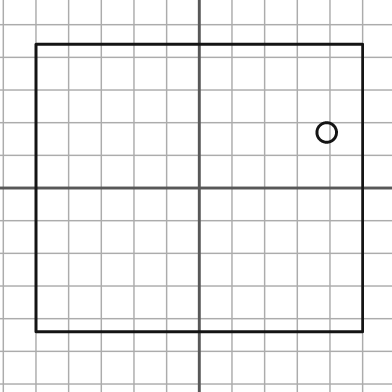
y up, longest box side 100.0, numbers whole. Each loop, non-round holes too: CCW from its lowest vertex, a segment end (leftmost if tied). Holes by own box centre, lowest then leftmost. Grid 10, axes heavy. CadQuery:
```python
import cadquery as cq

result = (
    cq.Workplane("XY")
    .moveTo(-50.0, -44.0)
    .lineTo(50.0, -44.0)
    .lineTo(50.0, 44.0)
    .lineTo(-50.0, 44.0)
    .close()
    .moveTo(39.0, 17.0)
    .circle(3.0)
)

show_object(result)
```